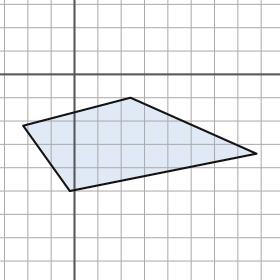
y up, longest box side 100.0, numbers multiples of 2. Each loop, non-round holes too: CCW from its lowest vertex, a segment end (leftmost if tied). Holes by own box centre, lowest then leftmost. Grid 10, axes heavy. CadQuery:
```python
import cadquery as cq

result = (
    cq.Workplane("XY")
    .moveTo(-2.0, -50.0)
    .lineTo(78.0, -34.0)
    .lineTo(24.0, -10.0)
    .lineTo(-22.0, -22.0)
    .close()
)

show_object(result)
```